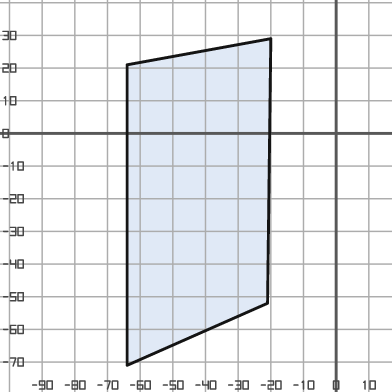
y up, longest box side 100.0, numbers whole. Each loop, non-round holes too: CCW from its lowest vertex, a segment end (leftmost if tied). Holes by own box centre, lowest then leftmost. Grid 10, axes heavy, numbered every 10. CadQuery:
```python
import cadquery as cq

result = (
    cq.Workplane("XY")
    .moveTo(-64.0, -71.0)
    .lineTo(-21.0, -52.0)
    .lineTo(-20.0, 29.0)
    .lineTo(-64.0, 21.0)
    .close()
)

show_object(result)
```